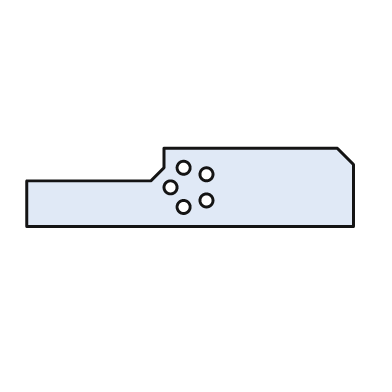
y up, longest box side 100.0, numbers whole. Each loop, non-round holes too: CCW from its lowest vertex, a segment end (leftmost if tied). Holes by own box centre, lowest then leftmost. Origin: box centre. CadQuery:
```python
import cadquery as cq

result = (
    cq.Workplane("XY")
    .moveTo(-50.0, -12.0)
    .lineTo(50.0, -12.0)
    .lineTo(50.0, 7.0)
    .lineTo(45.0, 12.0)
    .lineTo(-8.0, 12.0)
    .lineTo(-8.0, 6.0)
    .lineTo(-12.0, 2.0)
    .lineTo(-50.0, 2.0)
    .close()
    .moveTo(-2.0, -6.0)
    .circle(2.0)
    .moveTo(5.0, -4.0)
    .circle(2.0)
    .moveTo(-6.0, 0.0)
    .circle(2.0)
    .moveTo(5.0, 4.0)
    .circle(2.0)
    .moveTo(-2.0, 6.0)
    .circle(2.0)
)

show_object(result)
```